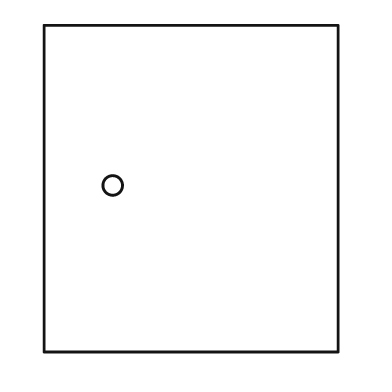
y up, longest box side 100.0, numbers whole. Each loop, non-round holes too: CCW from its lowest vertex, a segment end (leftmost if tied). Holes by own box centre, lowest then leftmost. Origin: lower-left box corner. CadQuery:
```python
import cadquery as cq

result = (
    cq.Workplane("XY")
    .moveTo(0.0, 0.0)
    .lineTo(90.0, 0.0)
    .lineTo(90.0, 100.0)
    .lineTo(0.0, 100.0)
    .close()
    .moveTo(21.0, 51.0)
    .circle(3.0)
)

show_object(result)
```